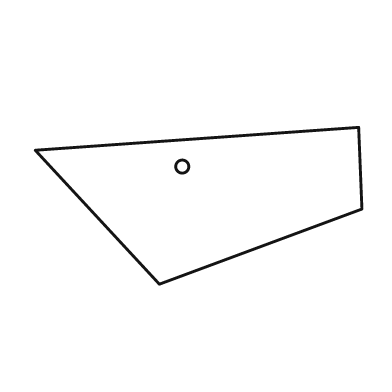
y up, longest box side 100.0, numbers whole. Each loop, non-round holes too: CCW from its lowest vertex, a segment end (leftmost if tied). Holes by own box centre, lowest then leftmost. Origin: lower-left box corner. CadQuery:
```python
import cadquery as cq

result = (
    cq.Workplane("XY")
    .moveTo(38.0, 0.0)
    .lineTo(100.0, 23.0)
    .lineTo(99.0, 48.0)
    .lineTo(0.0, 41.0)
    .close()
    .moveTo(45.0, 36.0)
    .circle(2.0)
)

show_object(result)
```